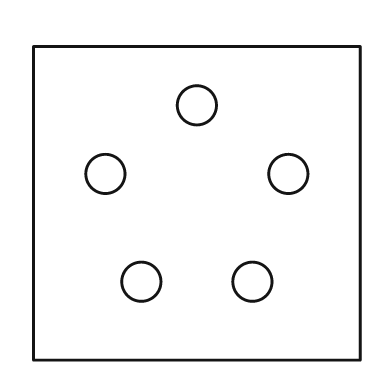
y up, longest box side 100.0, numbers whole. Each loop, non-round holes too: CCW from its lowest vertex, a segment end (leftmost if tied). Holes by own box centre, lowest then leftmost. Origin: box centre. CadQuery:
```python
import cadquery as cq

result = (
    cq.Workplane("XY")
    .moveTo(-50.0, -48.0)
    .lineTo(50.0, -48.0)
    .lineTo(50.0, 48.0)
    .lineTo(-50.0, 48.0)
    .close()
    .moveTo(-17.0, -24.0)
    .circle(6.0)
    .moveTo(17.0, -24.0)
    .circle(6.0)
    .moveTo(-28.0, 9.0)
    .circle(6.0)
    .moveTo(28.0, 9.0)
    .circle(6.0)
    .moveTo(0.0, 30.0)
    .circle(6.0)
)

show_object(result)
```